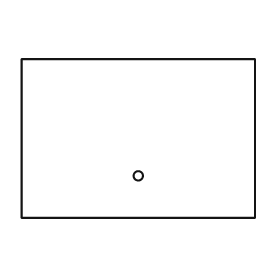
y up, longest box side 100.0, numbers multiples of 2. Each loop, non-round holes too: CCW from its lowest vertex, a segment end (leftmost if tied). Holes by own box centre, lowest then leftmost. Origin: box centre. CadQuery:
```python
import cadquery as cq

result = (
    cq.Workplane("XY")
    .moveTo(-50.0, -34.0)
    .lineTo(50.0, -34.0)
    .lineTo(50.0, 34.0)
    .lineTo(-50.0, 34.0)
    .close()
    .moveTo(0.0, -16.0)
    .circle(2.0)
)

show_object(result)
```